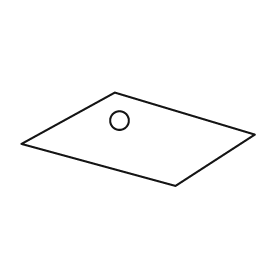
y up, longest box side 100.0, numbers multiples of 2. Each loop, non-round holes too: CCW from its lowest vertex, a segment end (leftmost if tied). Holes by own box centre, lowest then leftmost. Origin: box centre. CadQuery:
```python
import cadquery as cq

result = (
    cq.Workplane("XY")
    .moveTo(16.0, -20.0)
    .lineTo(50.0, 2.0)
    .lineTo(-10.0, 20.0)
    .lineTo(-50.0, -2.0)
    .close()
    .moveTo(-8.0, 8.0)
    .circle(4.0)
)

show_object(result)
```